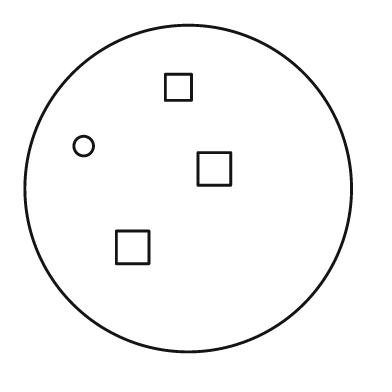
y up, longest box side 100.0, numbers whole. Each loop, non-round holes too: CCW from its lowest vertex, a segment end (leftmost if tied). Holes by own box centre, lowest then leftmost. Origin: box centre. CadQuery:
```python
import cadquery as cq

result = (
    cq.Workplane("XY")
    .moveTo(0.0, 0.0)
    .circle(50.0)
    .moveTo(-22.0, -23.0)
    .lineTo(-12.0, -23.0)
    .lineTo(-12.0, -13.0)
    .lineTo(-22.0, -13.0)
    .close()
    .moveTo(3.0, 1.0)
    .lineTo(13.0, 1.0)
    .lineTo(13.0, 11.0)
    .lineTo(3.0, 11.0)
    .close()
    .moveTo(-32.0, 13.0)
    .circle(3.0)
    .moveTo(-7.0, 27.0)
    .lineTo(1.0, 27.0)
    .lineTo(1.0, 35.0)
    .lineTo(-7.0, 35.0)
    .close()
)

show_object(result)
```